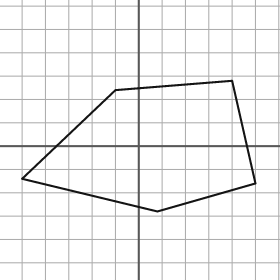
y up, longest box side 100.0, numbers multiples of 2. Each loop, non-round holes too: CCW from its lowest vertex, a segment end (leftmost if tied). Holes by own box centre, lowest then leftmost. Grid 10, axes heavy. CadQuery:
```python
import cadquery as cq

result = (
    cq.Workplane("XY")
    .moveTo(8.0, -28.0)
    .lineTo(50.0, -16.0)
    .lineTo(40.0, 28.0)
    .lineTo(-10.0, 24.0)
    .lineTo(-50.0, -14.0)
    .close()
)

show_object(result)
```